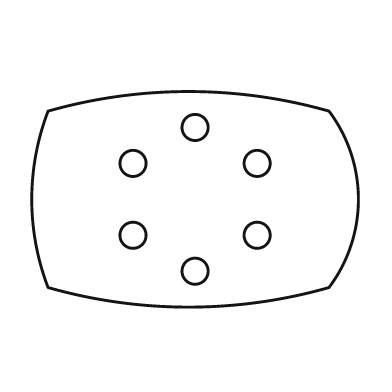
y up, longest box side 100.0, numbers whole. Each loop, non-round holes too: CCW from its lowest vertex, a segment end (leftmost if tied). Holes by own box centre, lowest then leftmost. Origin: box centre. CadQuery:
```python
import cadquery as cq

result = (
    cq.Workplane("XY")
    .moveTo(-45.0, -27.0)
    .threePointArc((-2.0, -33.0), (41.0, -27.0))
    .threePointArc((50.0, 0.0), (41.0, 27.0))
    .threePointArc((-2.0, 33.0), (-45.0, 27.0))
    .threePointArc((-50.0, 0.0), (-45.0, -27.0))
    .close()
    .moveTo(0.0, -22.0)
    .circle(4.0)
    .moveTo(-19.0, -11.0)
    .circle(4.0)
    .moveTo(19.0, -11.0)
    .circle(4.0)
    .moveTo(-19.0, 11.0)
    .circle(4.0)
    .moveTo(19.0, 11.0)
    .circle(4.0)
    .moveTo(0.0, 22.0)
    .circle(4.0)
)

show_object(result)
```